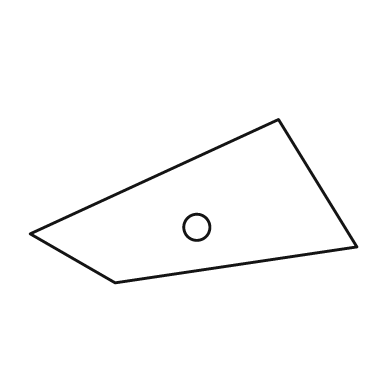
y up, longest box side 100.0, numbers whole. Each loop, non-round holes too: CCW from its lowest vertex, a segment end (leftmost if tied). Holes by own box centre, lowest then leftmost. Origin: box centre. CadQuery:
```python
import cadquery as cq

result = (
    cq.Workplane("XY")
    .moveTo(-24.0, -25.0)
    .lineTo(50.0, -14.0)
    .lineTo(26.0, 25.0)
    .lineTo(-50.0, -10.0)
    .close()
    .moveTo(1.0, -8.0)
    .circle(4.0)
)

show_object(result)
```